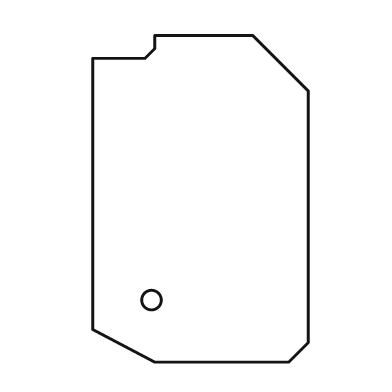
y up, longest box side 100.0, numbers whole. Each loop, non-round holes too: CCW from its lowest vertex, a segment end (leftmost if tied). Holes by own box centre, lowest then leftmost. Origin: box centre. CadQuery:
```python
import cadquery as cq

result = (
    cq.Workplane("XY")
    .moveTo(-14.0, -50.0)
    .lineTo(27.0, -50.0)
    .lineTo(33.0, -44.0)
    .lineTo(33.0, 33.0)
    .lineTo(16.0, 50.0)
    .lineTo(-14.0, 50.0)
    .lineTo(-14.0, 46.0)
    .lineTo(-17.0, 43.0)
    .lineTo(-33.0, 43.0)
    .lineTo(-33.0, -40.0)
    .close()
    .moveTo(-15.0, -31.0)
    .circle(3.0)
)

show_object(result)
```